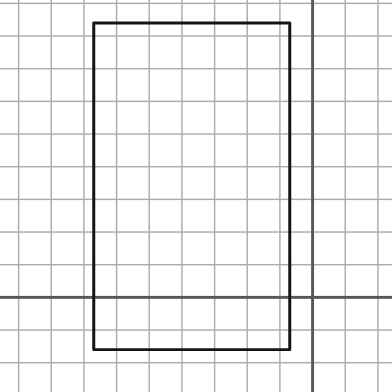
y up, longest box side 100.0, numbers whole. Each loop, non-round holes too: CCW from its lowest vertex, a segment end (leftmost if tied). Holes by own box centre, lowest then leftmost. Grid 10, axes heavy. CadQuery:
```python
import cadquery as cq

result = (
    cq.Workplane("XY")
    .moveTo(-67.0, -16.0)
    .lineTo(-7.0, -16.0)
    .lineTo(-7.0, 84.0)
    .lineTo(-67.0, 84.0)
    .close()
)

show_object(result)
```